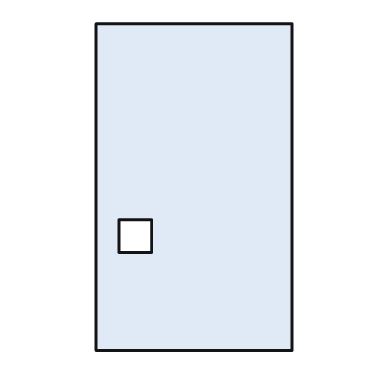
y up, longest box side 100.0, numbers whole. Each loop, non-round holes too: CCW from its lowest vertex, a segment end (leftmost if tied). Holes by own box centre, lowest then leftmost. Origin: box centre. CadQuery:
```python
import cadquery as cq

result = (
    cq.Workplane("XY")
    .moveTo(-30.0, -50.0)
    .lineTo(30.0, -50.0)
    .lineTo(30.0, 50.0)
    .lineTo(-30.0, 50.0)
    .close()
    .moveTo(-23.0, -20.0)
    .lineTo(-13.0, -20.0)
    .lineTo(-13.0, -10.0)
    .lineTo(-23.0, -10.0)
    .close()
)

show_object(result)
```